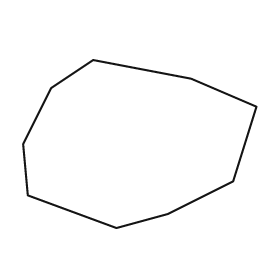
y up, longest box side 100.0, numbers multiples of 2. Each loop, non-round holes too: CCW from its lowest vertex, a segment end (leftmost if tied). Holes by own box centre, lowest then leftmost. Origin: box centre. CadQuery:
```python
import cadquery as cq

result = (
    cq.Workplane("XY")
    .moveTo(-10.0, -36.0)
    .lineTo(12.0, -30.0)
    .lineTo(40.0, -16.0)
    .lineTo(50.0, 16.0)
    .lineTo(22.0, 28.0)
    .lineTo(-20.0, 36.0)
    .lineTo(-38.0, 24.0)
    .lineTo(-50.0, 0.0)
    .lineTo(-48.0, -22.0)
    .close()
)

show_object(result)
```